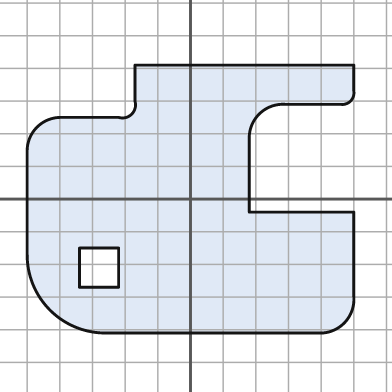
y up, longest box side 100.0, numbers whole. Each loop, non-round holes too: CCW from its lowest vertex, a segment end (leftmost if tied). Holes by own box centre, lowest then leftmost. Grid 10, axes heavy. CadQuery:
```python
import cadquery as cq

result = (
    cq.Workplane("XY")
    .moveTo(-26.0, -41.0)
    .lineTo(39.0, -41.0)
    .threePointArc((47.0, -38.0), (50.0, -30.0))
    .lineTo(50.0, -4.0)
    .lineTo(18.0, -4.0)
    .lineTo(18.0, 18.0)
    .threePointArc((21.0, 26.0), (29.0, 29.0))
    .lineTo(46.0, 29.0)
    .threePointArc((49.0, 30.0), (50.0, 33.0))
    .lineTo(50.0, 41.0)
    .lineTo(-17.0, 41.0)
    .lineTo(-17.0, 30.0)
    .threePointArc((-18.0, 26.0), (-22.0, 25.0))
    .lineTo(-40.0, 25.0)
    .threePointArc((-47.0, 22.0), (-50.0, 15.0))
    .lineTo(-50.0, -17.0)
    .threePointArc((-43.0, -34.0), (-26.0, -41.0))
    .close()
    .moveTo(-34.0, -27.0)
    .lineTo(-22.0, -27.0)
    .lineTo(-22.0, -15.0)
    .lineTo(-34.0, -15.0)
    .close()
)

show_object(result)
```